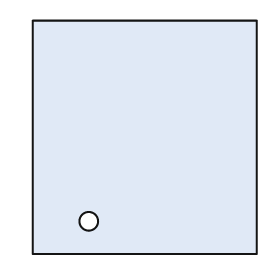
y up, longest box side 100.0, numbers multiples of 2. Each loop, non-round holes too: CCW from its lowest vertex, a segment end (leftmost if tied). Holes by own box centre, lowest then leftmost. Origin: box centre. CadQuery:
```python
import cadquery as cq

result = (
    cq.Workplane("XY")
    .moveTo(-48.0, -50.0)
    .lineTo(48.0, -50.0)
    .lineTo(48.0, 50.0)
    .lineTo(-48.0, 50.0)
    .close()
    .moveTo(-24.0, -36.0)
    .circle(4.0)
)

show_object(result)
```